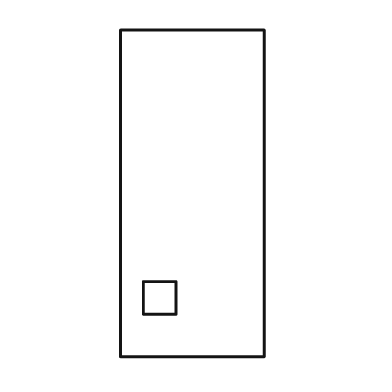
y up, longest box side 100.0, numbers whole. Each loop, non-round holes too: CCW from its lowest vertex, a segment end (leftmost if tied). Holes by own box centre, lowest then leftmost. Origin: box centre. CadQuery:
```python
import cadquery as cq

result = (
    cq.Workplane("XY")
    .moveTo(-22.0, -50.0)
    .lineTo(22.0, -50.0)
    .lineTo(22.0, 50.0)
    .lineTo(-22.0, 50.0)
    .close()
    .moveTo(-15.0, -37.0)
    .lineTo(-5.0, -37.0)
    .lineTo(-5.0, -27.0)
    .lineTo(-15.0, -27.0)
    .close()
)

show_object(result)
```